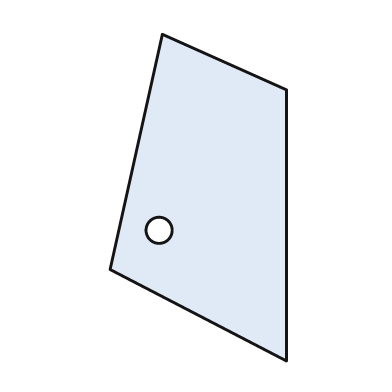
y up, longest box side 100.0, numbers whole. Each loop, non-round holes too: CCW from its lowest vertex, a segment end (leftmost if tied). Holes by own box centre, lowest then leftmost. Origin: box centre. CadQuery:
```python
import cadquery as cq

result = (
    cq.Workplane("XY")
    .moveTo(27.0, -50.0)
    .lineTo(27.0, 33.0)
    .lineTo(-11.0, 50.0)
    .lineTo(-27.0, -22.0)
    .close()
    .moveTo(-12.0, -10.0)
    .circle(4.0)
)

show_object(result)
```